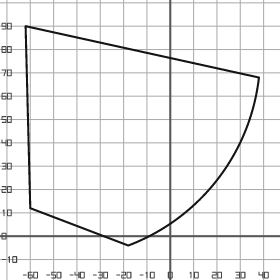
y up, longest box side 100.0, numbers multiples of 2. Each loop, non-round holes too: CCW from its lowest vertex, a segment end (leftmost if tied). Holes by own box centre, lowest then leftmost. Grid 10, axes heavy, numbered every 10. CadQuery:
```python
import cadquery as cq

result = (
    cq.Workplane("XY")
    .moveTo(-18.0, -4.0)
    .threePointArc((20.0, 24.0), (38.0, 68.0))
    .lineTo(-62.0, 90.0)
    .lineTo(-60.0, 12.0)
    .close()
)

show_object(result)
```